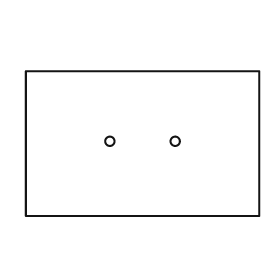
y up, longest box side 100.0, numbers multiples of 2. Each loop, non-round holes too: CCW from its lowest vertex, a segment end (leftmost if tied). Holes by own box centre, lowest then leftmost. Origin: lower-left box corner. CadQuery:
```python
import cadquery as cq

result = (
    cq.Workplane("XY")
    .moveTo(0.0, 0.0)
    .lineTo(100.0, 0.0)
    .lineTo(100.0, 62.0)
    .lineTo(0.0, 62.0)
    .close()
    .moveTo(36.0, 32.0)
    .circle(2.0)
    .moveTo(64.0, 32.0)
    .circle(2.0)
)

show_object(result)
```